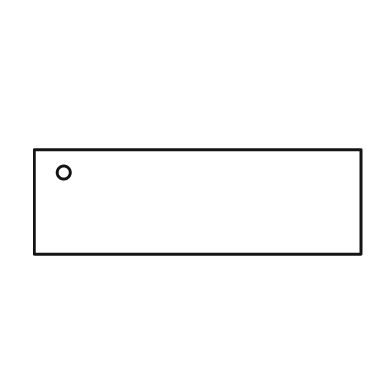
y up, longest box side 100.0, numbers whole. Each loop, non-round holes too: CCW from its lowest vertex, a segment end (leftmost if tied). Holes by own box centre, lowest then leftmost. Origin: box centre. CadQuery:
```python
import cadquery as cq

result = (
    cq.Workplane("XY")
    .moveTo(-50.0, -16.0)
    .lineTo(50.0, -16.0)
    .lineTo(50.0, 16.0)
    .lineTo(-50.0, 16.0)
    .close()
    .moveTo(-41.0, 9.0)
    .circle(2.0)
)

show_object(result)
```